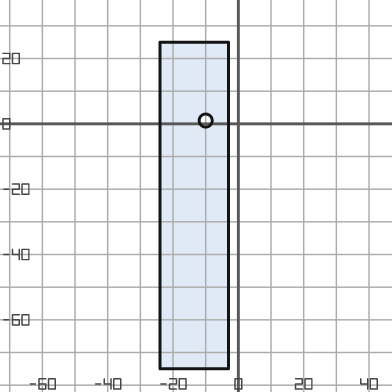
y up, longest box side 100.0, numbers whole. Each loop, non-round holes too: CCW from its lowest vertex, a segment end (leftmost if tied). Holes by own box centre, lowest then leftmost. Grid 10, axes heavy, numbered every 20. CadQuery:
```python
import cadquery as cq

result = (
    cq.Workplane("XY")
    .moveTo(-24.0, -75.0)
    .lineTo(-3.0, -75.0)
    .lineTo(-3.0, 25.0)
    .lineTo(-24.0, 25.0)
    .close()
    .moveTo(-10.0, 1.0)
    .circle(2.0)
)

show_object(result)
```